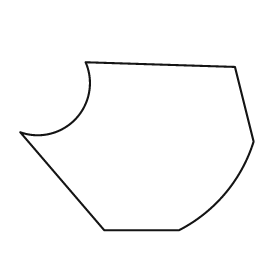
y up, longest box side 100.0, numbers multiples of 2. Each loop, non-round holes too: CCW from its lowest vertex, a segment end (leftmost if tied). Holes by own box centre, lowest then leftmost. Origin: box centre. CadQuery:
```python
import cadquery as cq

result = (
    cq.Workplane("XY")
    .moveTo(-14.0, -36.0)
    .lineTo(18.0, -36.0)
    .threePointArc((38.0, -20.0), (50.0, 2.0))
    .lineTo(42.0, 34.0)
    .lineTo(-22.0, 36.0)
    .threePointArc((-26.0, 12.0), (-50.0, 6.0))
    .close()
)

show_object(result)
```